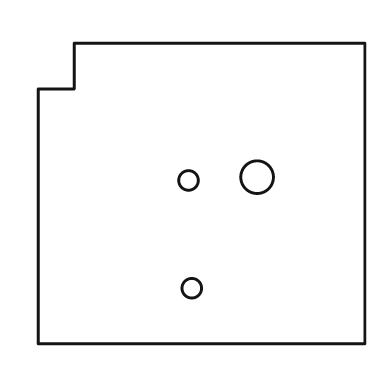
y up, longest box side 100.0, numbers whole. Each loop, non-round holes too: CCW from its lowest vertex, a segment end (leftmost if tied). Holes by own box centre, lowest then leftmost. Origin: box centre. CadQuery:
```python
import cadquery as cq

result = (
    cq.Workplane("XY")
    .moveTo(-50.0, -46.0)
    .lineTo(50.0, -46.0)
    .lineTo(50.0, 46.0)
    .lineTo(-39.0, 46.0)
    .lineTo(-39.0, 32.0)
    .lineTo(-50.0, 32.0)
    .close()
    .moveTo(-3.0, -29.0)
    .circle(3.0)
    .moveTo(-4.0, 4.0)
    .circle(3.0)
    .moveTo(17.0, 5.0)
    .circle(5.0)
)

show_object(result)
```